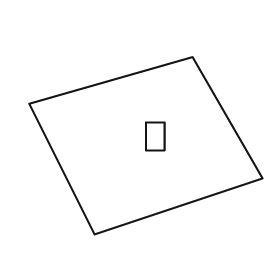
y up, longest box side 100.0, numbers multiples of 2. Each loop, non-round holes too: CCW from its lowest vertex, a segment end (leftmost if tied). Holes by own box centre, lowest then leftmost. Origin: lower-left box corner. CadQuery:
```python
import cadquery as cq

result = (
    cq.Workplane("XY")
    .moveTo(28.0, 0.0)
    .lineTo(100.0, 24.0)
    .lineTo(70.0, 76.0)
    .lineTo(0.0, 56.0)
    .close()
    .moveTo(50.0, 36.0)
    .lineTo(58.0, 36.0)
    .lineTo(58.0, 48.0)
    .lineTo(50.0, 48.0)
    .close()
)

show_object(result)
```